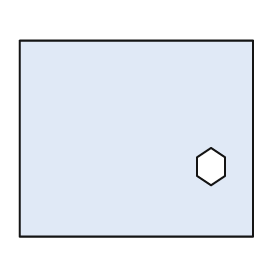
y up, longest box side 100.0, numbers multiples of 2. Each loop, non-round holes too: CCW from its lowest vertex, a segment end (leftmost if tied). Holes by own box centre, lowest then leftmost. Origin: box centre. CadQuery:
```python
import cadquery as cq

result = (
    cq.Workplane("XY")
    .moveTo(-50.0, -42.0)
    .lineTo(50.0, -42.0)
    .lineTo(50.0, 42.0)
    .lineTo(-50.0, 42.0)
    .close()
    .moveTo(32.0, -20.0)
    .lineTo(38.0, -16.0)
    .lineTo(38.0, -8.0)
    .lineTo(32.0, -4.0)
    .lineTo(26.0, -8.0)
    .lineTo(26.0, -16.0)
    .close()
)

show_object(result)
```